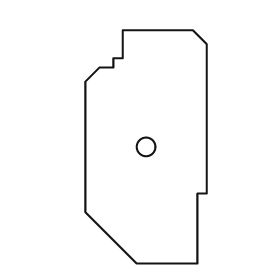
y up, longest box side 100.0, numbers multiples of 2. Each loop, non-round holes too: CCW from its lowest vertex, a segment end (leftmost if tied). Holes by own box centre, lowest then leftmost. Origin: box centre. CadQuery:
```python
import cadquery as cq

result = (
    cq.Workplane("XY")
    .moveTo(-4.0, -50.0)
    .lineTo(22.0, -50.0)
    .lineTo(22.0, -20.0)
    .lineTo(26.0, -20.0)
    .lineTo(26.0, 44.0)
    .lineTo(20.0, 50.0)
    .lineTo(-10.0, 50.0)
    .lineTo(-10.0, 38.0)
    .lineTo(-14.0, 38.0)
    .lineTo(-14.0, 34.0)
    .lineTo(-20.0, 34.0)
    .lineTo(-26.0, 28.0)
    .lineTo(-26.0, -28.0)
    .close()
    .moveTo(0.0, 0.0)
    .circle(4.0)
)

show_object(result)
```